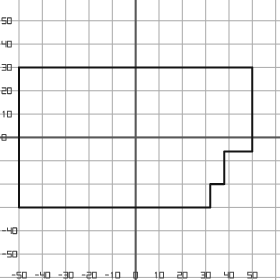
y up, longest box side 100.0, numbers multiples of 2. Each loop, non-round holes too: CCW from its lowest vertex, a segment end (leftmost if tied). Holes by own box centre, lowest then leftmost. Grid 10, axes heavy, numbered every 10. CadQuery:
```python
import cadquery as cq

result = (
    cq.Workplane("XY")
    .moveTo(-50.0, -30.0)
    .lineTo(32.0, -30.0)
    .lineTo(32.0, -20.0)
    .lineTo(38.0, -20.0)
    .lineTo(38.0, -6.0)
    .lineTo(50.0, -6.0)
    .lineTo(50.0, 30.0)
    .lineTo(-50.0, 30.0)
    .close()
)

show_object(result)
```